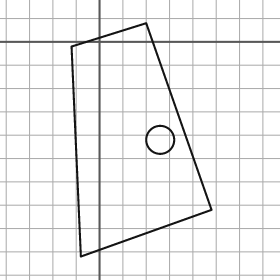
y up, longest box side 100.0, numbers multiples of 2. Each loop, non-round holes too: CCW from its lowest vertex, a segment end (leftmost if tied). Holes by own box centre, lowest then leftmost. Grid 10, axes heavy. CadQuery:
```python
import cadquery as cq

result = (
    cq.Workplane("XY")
    .moveTo(-8.0, -92.0)
    .lineTo(48.0, -72.0)
    .lineTo(20.0, 8.0)
    .lineTo(-12.0, -2.0)
    .close()
    .moveTo(26.0, -42.0)
    .circle(6.0)
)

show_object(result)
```